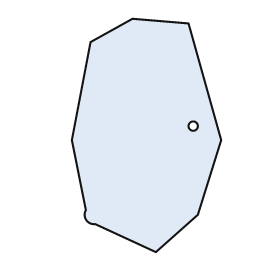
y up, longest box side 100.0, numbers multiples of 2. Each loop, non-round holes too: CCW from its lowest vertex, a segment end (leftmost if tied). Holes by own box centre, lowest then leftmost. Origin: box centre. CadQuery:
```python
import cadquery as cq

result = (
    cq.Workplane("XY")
    .moveTo(4.0, -50.0)
    .lineTo(22.0, -34.0)
    .lineTo(32.0, -2.0)
    .lineTo(18.0, 48.0)
    .lineTo(-6.0, 50.0)
    .lineTo(-24.0, 40.0)
    .lineTo(-32.0, -2.0)
    .lineTo(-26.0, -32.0)
    .threePointArc((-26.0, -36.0), (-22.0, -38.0))
    .close()
    .moveTo(20.0, 4.0)
    .circle(2.0)
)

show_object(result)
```